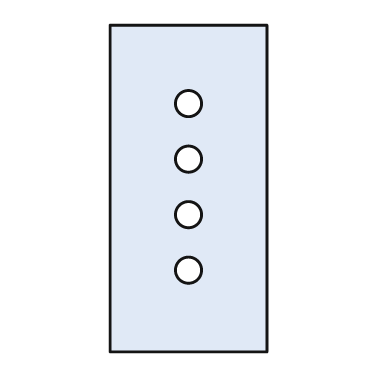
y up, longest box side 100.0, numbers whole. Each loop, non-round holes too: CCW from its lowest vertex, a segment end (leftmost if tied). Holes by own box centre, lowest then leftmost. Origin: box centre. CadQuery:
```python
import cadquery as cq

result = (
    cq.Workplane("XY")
    .moveTo(-24.0, -50.0)
    .lineTo(24.0, -50.0)
    .lineTo(24.0, 50.0)
    .lineTo(-24.0, 50.0)
    .close()
    .moveTo(0.0, -25.0)
    .circle(4.0)
    .moveTo(0.0, -8.0)
    .circle(4.0)
    .moveTo(0.0, 9.0)
    .circle(4.0)
    .moveTo(0.0, 26.0)
    .circle(4.0)
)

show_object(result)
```